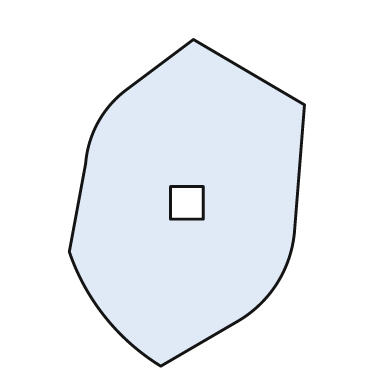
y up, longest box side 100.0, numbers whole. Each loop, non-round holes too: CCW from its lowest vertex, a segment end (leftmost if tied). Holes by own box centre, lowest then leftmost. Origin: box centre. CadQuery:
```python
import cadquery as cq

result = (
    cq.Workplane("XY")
    .moveTo(-8.0, -50.0)
    .lineTo(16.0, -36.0)
    .threePointArc((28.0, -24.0), (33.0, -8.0))
    .lineTo(36.0, 30.0)
    .lineTo(2.0, 50.0)
    .lineTo(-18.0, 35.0)
    .threePointArc((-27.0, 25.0), (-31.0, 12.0))
    .lineTo(-36.0, -15.0)
    .threePointArc((-25.0, -35.0), (-8.0, -50.0))
    .close()
    .moveTo(-5.0, -5.0)
    .lineTo(5.0, -5.0)
    .lineTo(5.0, 5.0)
    .lineTo(-5.0, 5.0)
    .close()
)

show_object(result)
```